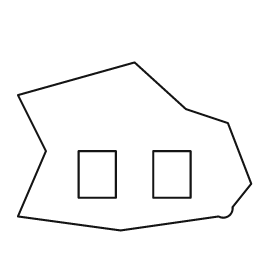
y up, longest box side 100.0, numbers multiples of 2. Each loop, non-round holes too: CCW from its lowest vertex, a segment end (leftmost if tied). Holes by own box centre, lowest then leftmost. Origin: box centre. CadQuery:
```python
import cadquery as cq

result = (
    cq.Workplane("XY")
    .moveTo(-6.0, -36.0)
    .lineTo(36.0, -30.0)
    .threePointArc((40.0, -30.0), (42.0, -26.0))
    .lineTo(50.0, -16.0)
    .lineTo(40.0, 10.0)
    .lineTo(22.0, 16.0)
    .lineTo(0.0, 36.0)
    .lineTo(-50.0, 22.0)
    .lineTo(-38.0, -2.0)
    .lineTo(-50.0, -30.0)
    .close()
    .moveTo(-24.0, -22.0)
    .lineTo(-8.0, -22.0)
    .lineTo(-8.0, -2.0)
    .lineTo(-24.0, -2.0)
    .close()
    .moveTo(8.0, -22.0)
    .lineTo(24.0, -22.0)
    .lineTo(24.0, -2.0)
    .lineTo(8.0, -2.0)
    .close()
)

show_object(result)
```